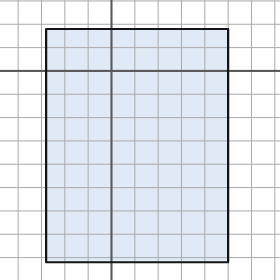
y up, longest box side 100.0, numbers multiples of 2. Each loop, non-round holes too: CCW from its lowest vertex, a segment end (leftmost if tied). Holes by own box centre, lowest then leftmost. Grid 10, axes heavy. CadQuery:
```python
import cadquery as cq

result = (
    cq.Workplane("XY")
    .moveTo(-28.0, -82.0)
    .lineTo(50.0, -82.0)
    .lineTo(50.0, 18.0)
    .lineTo(-28.0, 18.0)
    .close()
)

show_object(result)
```